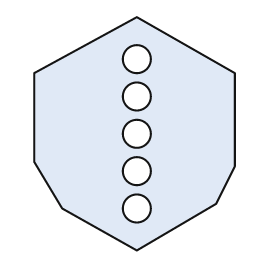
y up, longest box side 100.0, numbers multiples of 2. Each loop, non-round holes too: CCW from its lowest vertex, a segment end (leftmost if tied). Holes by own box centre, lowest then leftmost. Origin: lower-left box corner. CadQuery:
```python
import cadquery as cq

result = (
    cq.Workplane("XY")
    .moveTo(44.0, 0.0)
    .lineTo(78.0, 20.0)
    .lineTo(86.0, 36.0)
    .lineTo(86.0, 76.0)
    .lineTo(44.0, 100.0)
    .lineTo(0.0, 76.0)
    .lineTo(0.0, 38.0)
    .lineTo(12.0, 18.0)
    .close()
    .moveTo(44.0, 18.0)
    .circle(6.0)
    .moveTo(44.0, 34.0)
    .circle(6.0)
    .moveTo(44.0, 50.0)
    .circle(6.0)
    .moveTo(44.0, 66.0)
    .circle(6.0)
    .moveTo(44.0, 82.0)
    .circle(6.0)
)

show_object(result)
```